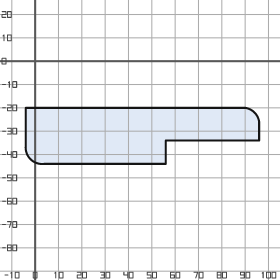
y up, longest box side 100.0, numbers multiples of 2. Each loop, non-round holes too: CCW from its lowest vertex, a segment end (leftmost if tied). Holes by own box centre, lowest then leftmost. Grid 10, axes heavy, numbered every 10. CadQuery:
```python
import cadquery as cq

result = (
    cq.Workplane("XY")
    .moveTo(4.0, -44.0)
    .lineTo(56.0, -44.0)
    .lineTo(56.0, -34.0)
    .lineTo(96.0, -34.0)
    .lineTo(96.0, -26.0)
    .threePointArc((94.0, -22.0), (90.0, -20.0))
    .lineTo(-4.0, -20.0)
    .lineTo(-4.0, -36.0)
    .threePointArc((-2.0, -42.0), (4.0, -44.0))
    .close()
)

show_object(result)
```